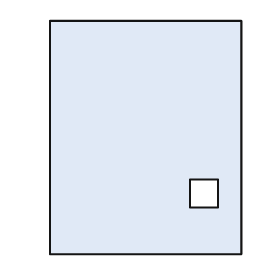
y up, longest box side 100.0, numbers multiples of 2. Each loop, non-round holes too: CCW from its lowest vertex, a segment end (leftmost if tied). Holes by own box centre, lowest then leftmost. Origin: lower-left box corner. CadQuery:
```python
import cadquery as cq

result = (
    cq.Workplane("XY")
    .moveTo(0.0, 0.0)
    .lineTo(82.0, 0.0)
    .lineTo(82.0, 100.0)
    .lineTo(0.0, 100.0)
    .close()
    .moveTo(60.0, 20.0)
    .lineTo(72.0, 20.0)
    .lineTo(72.0, 32.0)
    .lineTo(60.0, 32.0)
    .close()
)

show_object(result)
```